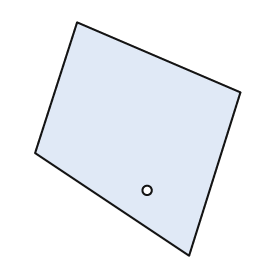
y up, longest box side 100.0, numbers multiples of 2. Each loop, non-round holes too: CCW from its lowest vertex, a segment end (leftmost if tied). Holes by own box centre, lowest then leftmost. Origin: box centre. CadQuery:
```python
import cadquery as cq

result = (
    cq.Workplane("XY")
    .moveTo(22.0, -50.0)
    .lineTo(44.0, 20.0)
    .lineTo(-26.0, 50.0)
    .lineTo(-44.0, -6.0)
    .close()
    .moveTo(4.0, -22.0)
    .circle(2.0)
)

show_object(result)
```